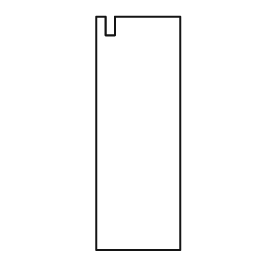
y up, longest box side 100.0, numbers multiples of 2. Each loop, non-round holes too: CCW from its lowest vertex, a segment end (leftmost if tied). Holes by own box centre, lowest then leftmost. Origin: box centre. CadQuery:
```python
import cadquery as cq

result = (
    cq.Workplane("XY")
    .moveTo(-18.0, -50.0)
    .lineTo(18.0, -50.0)
    .lineTo(18.0, 50.0)
    .lineTo(-10.0, 50.0)
    .lineTo(-10.0, 42.0)
    .lineTo(-14.0, 42.0)
    .lineTo(-14.0, 50.0)
    .lineTo(-18.0, 50.0)
    .close()
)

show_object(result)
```